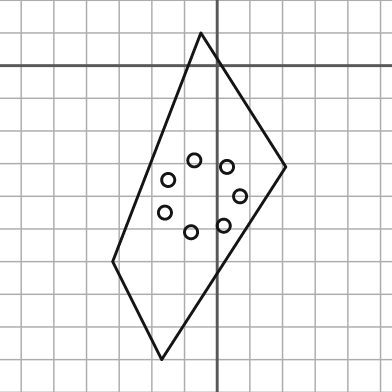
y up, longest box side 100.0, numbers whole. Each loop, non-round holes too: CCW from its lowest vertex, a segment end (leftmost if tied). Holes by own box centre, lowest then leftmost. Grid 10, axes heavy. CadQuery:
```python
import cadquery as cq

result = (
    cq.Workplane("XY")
    .moveTo(-17.0, -90.0)
    .lineTo(21.0, -31.0)
    .lineTo(-5.0, 10.0)
    .lineTo(-32.0, -60.0)
    .close()
    .moveTo(-8.0, -51.0)
    .circle(2.0)
    .moveTo(2.0, -49.0)
    .circle(2.0)
    .moveTo(-16.0, -45.0)
    .circle(2.0)
    .moveTo(7.0, -40.0)
    .circle(2.0)
    .moveTo(-15.0, -35.0)
    .circle(2.0)
    .moveTo(3.0, -31.0)
    .circle(2.0)
    .moveTo(-7.0, -29.0)
    .circle(2.0)
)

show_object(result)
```